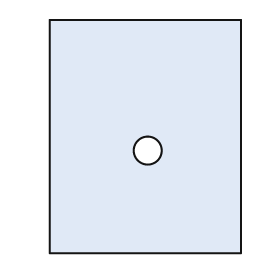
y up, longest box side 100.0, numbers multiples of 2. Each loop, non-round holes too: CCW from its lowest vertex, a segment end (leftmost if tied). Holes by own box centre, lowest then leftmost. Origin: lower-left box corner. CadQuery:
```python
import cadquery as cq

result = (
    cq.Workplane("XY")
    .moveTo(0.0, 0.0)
    .lineTo(82.0, 0.0)
    .lineTo(82.0, 100.0)
    .lineTo(0.0, 100.0)
    .close()
    .moveTo(42.0, 44.0)
    .circle(6.0)
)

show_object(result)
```